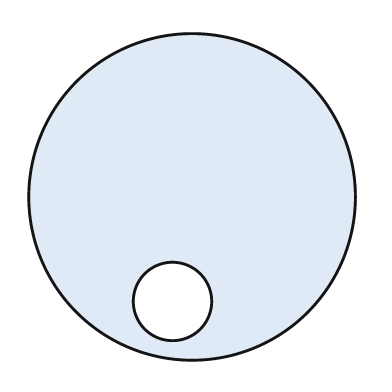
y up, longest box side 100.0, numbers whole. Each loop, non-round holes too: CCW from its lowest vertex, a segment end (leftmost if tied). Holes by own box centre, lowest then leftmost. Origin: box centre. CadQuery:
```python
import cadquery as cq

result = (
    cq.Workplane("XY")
    .moveTo(0.0, 0.0)
    .circle(50.0)
    .moveTo(-6.0, -32.0)
    .circle(12.0)
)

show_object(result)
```